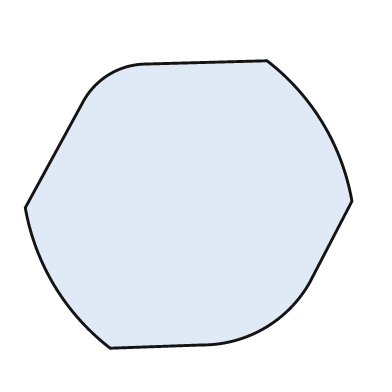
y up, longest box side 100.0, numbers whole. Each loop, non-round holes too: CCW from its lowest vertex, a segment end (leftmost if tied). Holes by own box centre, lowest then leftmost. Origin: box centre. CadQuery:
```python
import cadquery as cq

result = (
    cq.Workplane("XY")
    .moveTo(-24.0, -44.0)
    .lineTo(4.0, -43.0)
    .threePointArc((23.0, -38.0), (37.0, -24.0))
    .lineTo(50.0, 1.0)
    .threePointArc((41.0, 25.0), (24.0, 44.0))
    .lineTo(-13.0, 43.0)
    .threePointArc((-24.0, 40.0), (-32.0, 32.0))
    .lineTo(-50.0, -1.0)
    .threePointArc((-41.0, -25.0), (-24.0, -44.0))
    .close()
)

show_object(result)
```